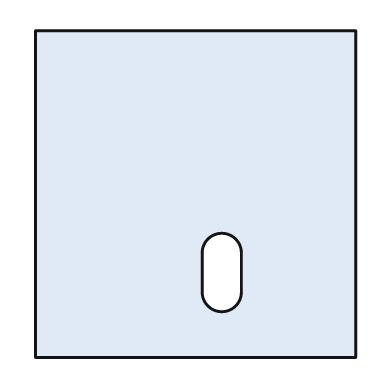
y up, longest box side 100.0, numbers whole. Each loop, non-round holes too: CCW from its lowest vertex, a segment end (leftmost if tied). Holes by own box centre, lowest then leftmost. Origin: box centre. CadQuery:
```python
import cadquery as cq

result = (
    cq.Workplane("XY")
    .moveTo(-49.0, -50.0)
    .lineTo(49.0, -50.0)
    .lineTo(49.0, 50.0)
    .lineTo(-49.0, 50.0)
    .close()
    .moveTo(2.0, -30.0)
    .threePointArc((8.0, -36.0), (14.0, -30.0))
    .lineTo(14.0, -18.0)
    .threePointArc((8.0, -12.0), (2.0, -18.0))
    .close()
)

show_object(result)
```